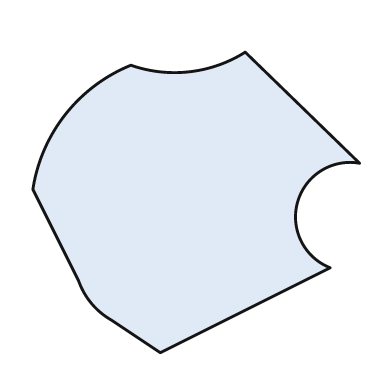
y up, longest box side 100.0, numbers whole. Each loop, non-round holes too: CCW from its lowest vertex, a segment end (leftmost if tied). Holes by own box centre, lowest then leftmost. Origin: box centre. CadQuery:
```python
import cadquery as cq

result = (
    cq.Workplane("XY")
    .moveTo(-11.0, -46.0)
    .lineTo(41.0, -20.0)
    .threePointArc((31.0, 0.0), (50.0, 12.0))
    .lineTo(15.0, 46.0)
    .threePointArc((-2.0, 40.0), (-20.0, 42.0))
    .threePointArc((-40.0, 27.0), (-50.0, 4.0))
    .lineTo(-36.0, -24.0)
    .threePointArc((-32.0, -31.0), (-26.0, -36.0))
    .close()
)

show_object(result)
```